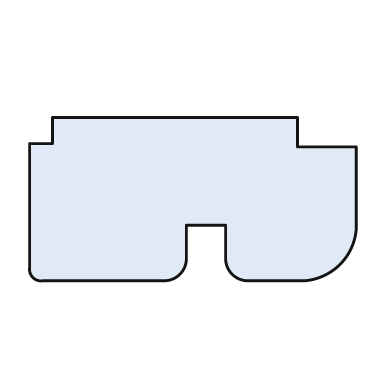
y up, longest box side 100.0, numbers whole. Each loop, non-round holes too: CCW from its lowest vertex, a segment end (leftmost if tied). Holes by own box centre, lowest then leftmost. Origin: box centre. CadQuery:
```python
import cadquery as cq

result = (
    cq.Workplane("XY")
    .moveTo(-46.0, -25.0)
    .lineTo(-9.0, -25.0)
    .threePointArc((-4.0, -23.0), (-2.0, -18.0))
    .lineTo(-2.0, -8.0)
    .lineTo(10.0, -8.0)
    .lineTo(10.0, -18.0)
    .threePointArc((12.0, -23.0), (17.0, -25.0))
    .lineTo(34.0, -25.0)
    .threePointArc((45.0, -20.0), (50.0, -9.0))
    .lineTo(50.0, 16.0)
    .lineTo(32.0, 16.0)
    .lineTo(32.0, 25.0)
    .lineTo(-43.0, 25.0)
    .lineTo(-43.0, 17.0)
    .lineTo(-50.0, 17.0)
    .lineTo(-50.0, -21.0)
    .threePointArc((-49.0, -24.0), (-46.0, -25.0))
    .close()
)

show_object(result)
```